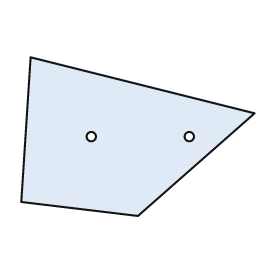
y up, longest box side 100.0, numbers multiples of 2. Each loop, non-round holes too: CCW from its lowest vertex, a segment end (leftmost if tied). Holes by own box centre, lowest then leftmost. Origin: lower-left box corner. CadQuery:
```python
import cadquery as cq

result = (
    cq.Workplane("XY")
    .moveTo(50.0, 0.0)
    .lineTo(100.0, 44.0)
    .lineTo(4.0, 68.0)
    .lineTo(0.0, 6.0)
    .close()
    .moveTo(30.0, 34.0)
    .circle(2.0)
    .moveTo(72.0, 34.0)
    .circle(2.0)
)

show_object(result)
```